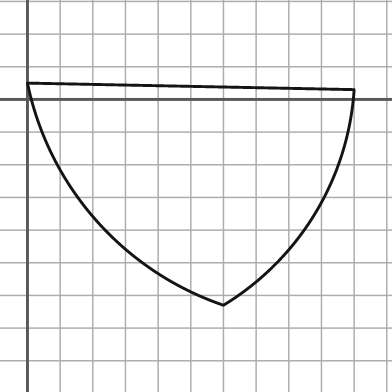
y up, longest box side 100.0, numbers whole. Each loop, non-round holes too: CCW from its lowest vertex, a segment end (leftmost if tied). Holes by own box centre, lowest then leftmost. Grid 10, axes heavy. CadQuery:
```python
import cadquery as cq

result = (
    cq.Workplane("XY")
    .moveTo(60.0, -63.0)
    .threePointArc((88.0, -35.0), (100.0, 3.0))
    .lineTo(0.0, 5.0)
    .threePointArc((21.0, -37.0), (60.0, -63.0))
    .close()
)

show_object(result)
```